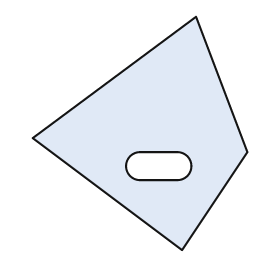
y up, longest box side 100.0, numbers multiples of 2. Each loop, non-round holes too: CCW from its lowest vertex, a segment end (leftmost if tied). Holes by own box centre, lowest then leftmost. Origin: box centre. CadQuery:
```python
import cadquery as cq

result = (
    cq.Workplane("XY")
    .moveTo(18.0, -50.0)
    .lineTo(46.0, -8.0)
    .lineTo(24.0, 50.0)
    .lineTo(-46.0, -2.0)
    .close()
    .moveTo(0.0, -20.0)
    .lineTo(16.0, -20.0)
    .threePointArc((22.0, -14.0), (16.0, -8.0))
    .lineTo(0.0, -8.0)
    .threePointArc((-6.0, -14.0), (0.0, -20.0))
    .close()
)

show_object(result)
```